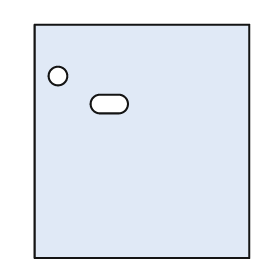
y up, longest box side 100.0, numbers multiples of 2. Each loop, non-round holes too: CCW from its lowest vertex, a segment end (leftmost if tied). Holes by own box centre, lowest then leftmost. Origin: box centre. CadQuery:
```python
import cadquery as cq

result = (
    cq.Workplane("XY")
    .moveTo(-46.0, -50.0)
    .lineTo(46.0, -50.0)
    .lineTo(46.0, 50.0)
    .lineTo(-46.0, 50.0)
    .close()
    .moveTo(-18.0, 12.0)
    .lineTo(-10.0, 12.0)
    .threePointArc((-6.0, 16.0), (-10.0, 20.0))
    .lineTo(-18.0, 20.0)
    .threePointArc((-22.0, 16.0), (-18.0, 12.0))
    .close()
    .moveTo(-36.0, 28.0)
    .circle(4.0)
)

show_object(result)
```